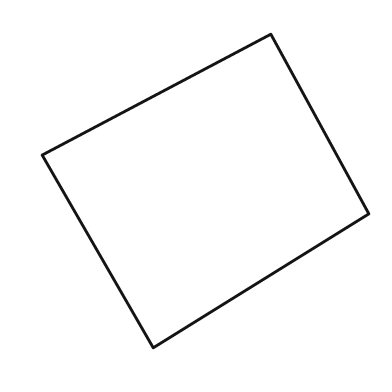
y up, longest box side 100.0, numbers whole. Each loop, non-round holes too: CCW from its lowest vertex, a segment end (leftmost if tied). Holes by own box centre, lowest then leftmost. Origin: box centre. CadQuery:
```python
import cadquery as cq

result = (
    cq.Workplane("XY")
    .moveTo(-16.0, -48.0)
    .lineTo(50.0, -7.0)
    .lineTo(20.0, 48.0)
    .lineTo(-50.0, 11.0)
    .close()
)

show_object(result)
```